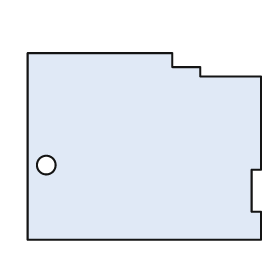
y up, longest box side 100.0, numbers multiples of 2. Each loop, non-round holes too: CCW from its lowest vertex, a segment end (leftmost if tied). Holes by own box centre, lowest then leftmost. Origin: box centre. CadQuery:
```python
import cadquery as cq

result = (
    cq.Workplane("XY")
    .moveTo(-50.0, -40.0)
    .lineTo(50.0, -40.0)
    .lineTo(50.0, -28.0)
    .lineTo(46.0, -28.0)
    .lineTo(46.0, -10.0)
    .lineTo(50.0, -10.0)
    .lineTo(50.0, 30.0)
    .lineTo(24.0, 30.0)
    .lineTo(24.0, 34.0)
    .lineTo(12.0, 34.0)
    .lineTo(12.0, 40.0)
    .lineTo(-50.0, 40.0)
    .close()
    .moveTo(-42.0, -8.0)
    .circle(4.0)
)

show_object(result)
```